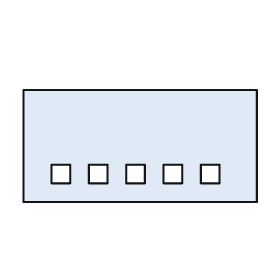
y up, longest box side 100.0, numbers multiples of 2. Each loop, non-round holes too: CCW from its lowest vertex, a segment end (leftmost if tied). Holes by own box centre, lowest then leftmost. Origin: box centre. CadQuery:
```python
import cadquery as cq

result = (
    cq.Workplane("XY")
    .moveTo(-50.0, -24.0)
    .lineTo(50.0, -24.0)
    .lineTo(50.0, 24.0)
    .lineTo(-50.0, 24.0)
    .close()
    .moveTo(-38.0, -16.0)
    .lineTo(-30.0, -16.0)
    .lineTo(-30.0, -8.0)
    .lineTo(-38.0, -8.0)
    .close()
    .moveTo(-22.0, -16.0)
    .lineTo(-14.0, -16.0)
    .lineTo(-14.0, -8.0)
    .lineTo(-22.0, -8.0)
    .close()
    .moveTo(-6.0, -16.0)
    .lineTo(2.0, -16.0)
    .lineTo(2.0, -8.0)
    .lineTo(-6.0, -8.0)
    .close()
    .moveTo(10.0, -16.0)
    .lineTo(18.0, -16.0)
    .lineTo(18.0, -8.0)
    .lineTo(10.0, -8.0)
    .close()
    .moveTo(26.0, -16.0)
    .lineTo(34.0, -16.0)
    .lineTo(34.0, -8.0)
    .lineTo(26.0, -8.0)
    .close()
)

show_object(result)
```